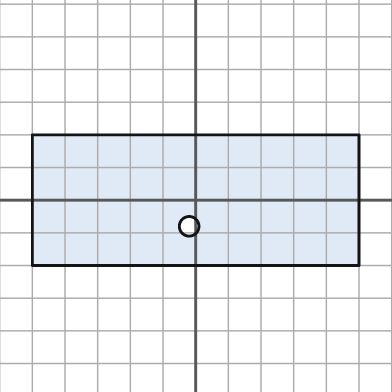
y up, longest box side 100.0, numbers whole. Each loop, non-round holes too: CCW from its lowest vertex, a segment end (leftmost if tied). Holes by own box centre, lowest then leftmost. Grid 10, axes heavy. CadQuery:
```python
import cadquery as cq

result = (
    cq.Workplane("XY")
    .moveTo(-50.0, -20.0)
    .lineTo(50.0, -20.0)
    .lineTo(50.0, 20.0)
    .lineTo(-50.0, 20.0)
    .close()
    .moveTo(-2.0, -8.0)
    .circle(3.0)
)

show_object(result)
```